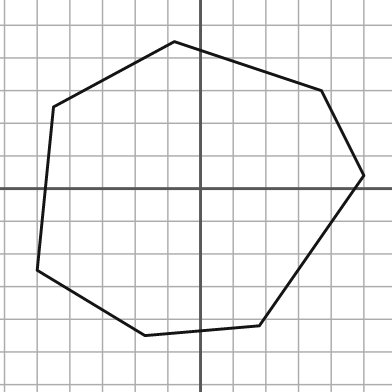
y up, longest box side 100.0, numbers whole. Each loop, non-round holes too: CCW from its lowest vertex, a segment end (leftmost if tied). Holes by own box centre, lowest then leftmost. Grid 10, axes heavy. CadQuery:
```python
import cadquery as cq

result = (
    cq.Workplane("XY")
    .moveTo(-17.0, -45.0)
    .lineTo(18.0, -42.0)
    .lineTo(50.0, 4.0)
    .lineTo(37.0, 30.0)
    .lineTo(-8.0, 45.0)
    .lineTo(-45.0, 25.0)
    .lineTo(-50.0, -25.0)
    .close()
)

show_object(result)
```